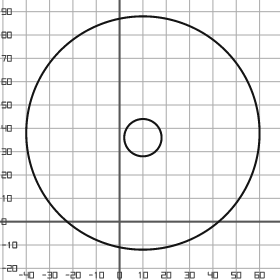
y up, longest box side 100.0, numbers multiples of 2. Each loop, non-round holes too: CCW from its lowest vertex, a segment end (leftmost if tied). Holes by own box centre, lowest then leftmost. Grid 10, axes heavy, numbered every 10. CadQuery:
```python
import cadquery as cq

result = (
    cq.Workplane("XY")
    .moveTo(10.0, 38.0)
    .circle(50.0)
    .moveTo(10.0, 36.0)
    .circle(8.0)
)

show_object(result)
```